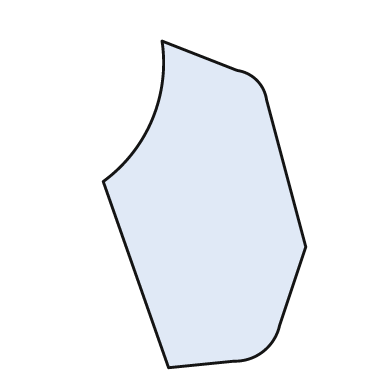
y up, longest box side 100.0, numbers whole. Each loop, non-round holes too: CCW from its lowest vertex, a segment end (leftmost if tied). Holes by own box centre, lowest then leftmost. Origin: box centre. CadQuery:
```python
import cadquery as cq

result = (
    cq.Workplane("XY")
    .moveTo(-11.0, -50.0)
    .lineTo(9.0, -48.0)
    .threePointArc((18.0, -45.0), (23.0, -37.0))
    .lineTo(31.0, -13.0)
    .lineTo(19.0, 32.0)
    .threePointArc((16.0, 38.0), (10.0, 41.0))
    .lineTo(-13.0, 50.0)
    .threePointArc((-16.0, 26.0), (-31.0, 7.0))
    .close()
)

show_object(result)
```